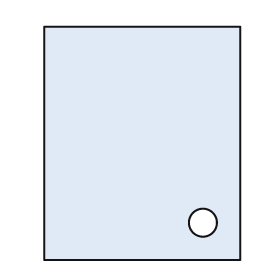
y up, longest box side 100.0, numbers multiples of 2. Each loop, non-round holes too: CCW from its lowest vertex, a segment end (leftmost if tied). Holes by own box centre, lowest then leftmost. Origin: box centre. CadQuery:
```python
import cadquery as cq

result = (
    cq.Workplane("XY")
    .moveTo(-42.0, -50.0)
    .lineTo(42.0, -50.0)
    .lineTo(42.0, 50.0)
    .lineTo(-42.0, 50.0)
    .close()
    .moveTo(26.0, -34.0)
    .circle(6.0)
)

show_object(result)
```